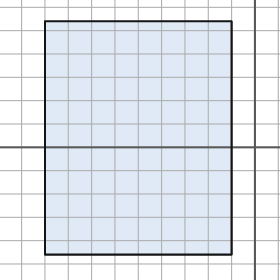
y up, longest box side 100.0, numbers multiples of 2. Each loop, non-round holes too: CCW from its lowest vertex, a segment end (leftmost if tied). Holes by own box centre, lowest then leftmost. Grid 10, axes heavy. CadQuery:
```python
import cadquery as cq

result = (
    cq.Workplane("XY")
    .moveTo(-90.0, -46.0)
    .lineTo(-10.0, -46.0)
    .lineTo(-10.0, 54.0)
    .lineTo(-90.0, 54.0)
    .close()
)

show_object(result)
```